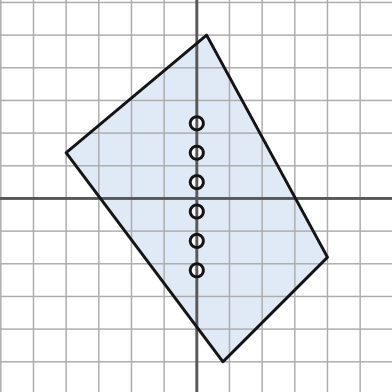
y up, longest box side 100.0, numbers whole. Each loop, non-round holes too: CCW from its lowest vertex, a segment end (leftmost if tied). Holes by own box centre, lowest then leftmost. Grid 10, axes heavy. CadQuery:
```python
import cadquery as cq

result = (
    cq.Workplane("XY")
    .moveTo(8.0, -50.0)
    .lineTo(40.0, -18.0)
    .lineTo(3.0, 50.0)
    .lineTo(-40.0, 14.0)
    .close()
    .moveTo(0.0, -22.0)
    .circle(2.0)
    .moveTo(0.0, -13.0)
    .circle(2.0)
    .moveTo(0.0, -4.0)
    .circle(2.0)
    .moveTo(0.0, 5.0)
    .circle(2.0)
    .moveTo(0.0, 14.0)
    .circle(2.0)
    .moveTo(0.0, 23.0)
    .circle(2.0)
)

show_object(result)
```